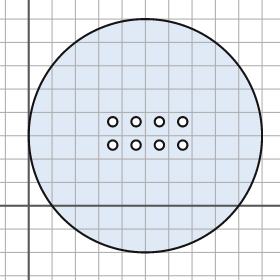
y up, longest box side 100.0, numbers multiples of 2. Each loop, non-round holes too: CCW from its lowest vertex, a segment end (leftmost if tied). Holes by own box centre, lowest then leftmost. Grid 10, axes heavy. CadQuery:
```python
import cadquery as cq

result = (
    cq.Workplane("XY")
    .moveTo(50.0, 30.0)
    .circle(50.0)
    .moveTo(36.0, 26.0)
    .circle(2.0)
    .moveTo(46.0, 26.0)
    .circle(2.0)
    .moveTo(56.0, 26.0)
    .circle(2.0)
    .moveTo(66.0, 26.0)
    .circle(2.0)
    .moveTo(36.0, 36.0)
    .circle(2.0)
    .moveTo(46.0, 36.0)
    .circle(2.0)
    .moveTo(56.0, 36.0)
    .circle(2.0)
    .moveTo(66.0, 36.0)
    .circle(2.0)
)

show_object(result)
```